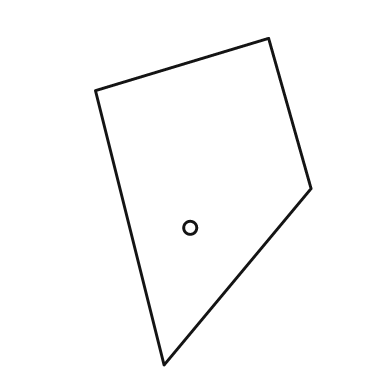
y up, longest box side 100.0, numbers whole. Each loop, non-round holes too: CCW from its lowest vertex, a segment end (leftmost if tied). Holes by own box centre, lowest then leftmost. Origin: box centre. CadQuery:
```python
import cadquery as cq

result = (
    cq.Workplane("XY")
    .moveTo(-12.0, -50.0)
    .lineTo(33.0, 4.0)
    .lineTo(20.0, 50.0)
    .lineTo(-33.0, 34.0)
    .close()
    .moveTo(-4.0, -8.0)
    .circle(2.0)
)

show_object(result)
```